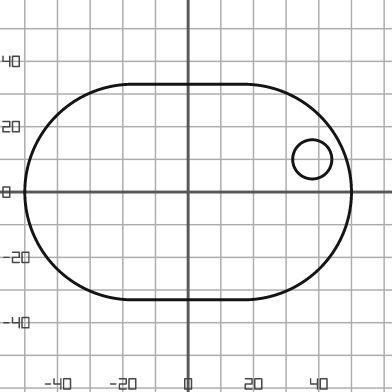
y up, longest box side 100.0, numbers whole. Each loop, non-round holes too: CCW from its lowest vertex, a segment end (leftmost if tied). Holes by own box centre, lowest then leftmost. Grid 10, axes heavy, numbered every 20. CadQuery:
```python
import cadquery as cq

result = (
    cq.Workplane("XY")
    .moveTo(-17.0, -33.0)
    .lineTo(17.0, -33.0)
    .threePointArc((50.0, 0.0), (17.0, 33.0))
    .lineTo(-17.0, 33.0)
    .threePointArc((-50.0, 0.0), (-17.0, -33.0))
    .close()
    .moveTo(38.0, 10.0)
    .circle(6.0)
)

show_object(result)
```